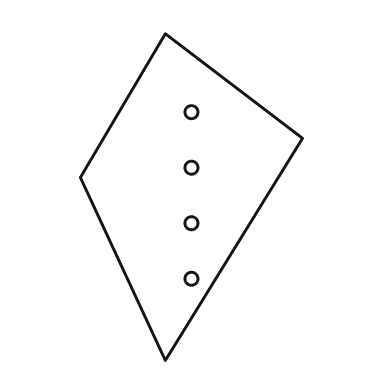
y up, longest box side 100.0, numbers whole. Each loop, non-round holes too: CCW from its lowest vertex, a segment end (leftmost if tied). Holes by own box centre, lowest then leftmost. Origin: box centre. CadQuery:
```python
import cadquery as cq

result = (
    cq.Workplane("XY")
    .moveTo(-8.0, -50.0)
    .lineTo(34.0, 18.0)
    .lineTo(-8.0, 50.0)
    .lineTo(-34.0, 6.0)
    .close()
    .moveTo(0.0, -25.0)
    .circle(2.0)
    .moveTo(0.0, -8.0)
    .circle(2.0)
    .moveTo(0.0, 9.0)
    .circle(2.0)
    .moveTo(0.0, 26.0)
    .circle(2.0)
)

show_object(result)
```